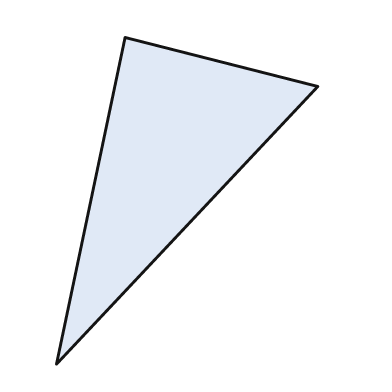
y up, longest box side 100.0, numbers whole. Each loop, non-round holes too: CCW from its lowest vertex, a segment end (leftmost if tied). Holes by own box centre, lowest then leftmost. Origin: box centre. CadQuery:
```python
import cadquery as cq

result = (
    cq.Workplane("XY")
    .moveTo(-40.0, -50.0)
    .lineTo(40.0, 35.0)
    .lineTo(-19.0, 50.0)
    .close()
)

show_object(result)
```